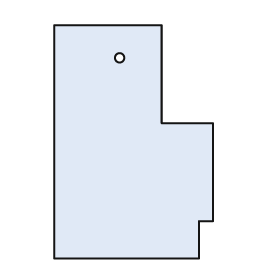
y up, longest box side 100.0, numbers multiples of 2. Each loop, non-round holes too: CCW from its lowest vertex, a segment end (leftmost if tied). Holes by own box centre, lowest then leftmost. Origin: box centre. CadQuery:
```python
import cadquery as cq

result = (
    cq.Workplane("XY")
    .moveTo(-34.0, -50.0)
    .lineTo(28.0, -50.0)
    .lineTo(28.0, -34.0)
    .lineTo(34.0, -34.0)
    .lineTo(34.0, 8.0)
    .lineTo(12.0, 8.0)
    .lineTo(12.0, 50.0)
    .lineTo(-34.0, 50.0)
    .close()
    .moveTo(-6.0, 36.0)
    .circle(2.0)
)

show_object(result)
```